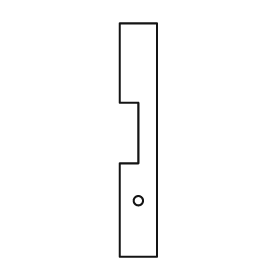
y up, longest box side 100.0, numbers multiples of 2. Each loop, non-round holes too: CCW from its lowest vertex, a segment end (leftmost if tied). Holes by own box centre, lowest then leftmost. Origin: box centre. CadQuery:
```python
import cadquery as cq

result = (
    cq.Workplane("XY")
    .moveTo(-8.0, -50.0)
    .lineTo(8.0, -50.0)
    .lineTo(8.0, 50.0)
    .lineTo(-8.0, 50.0)
    .lineTo(-8.0, 16.0)
    .lineTo(0.0, 16.0)
    .lineTo(0.0, -10.0)
    .lineTo(-8.0, -10.0)
    .close()
    .moveTo(0.0, -26.0)
    .circle(2.0)
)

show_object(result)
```